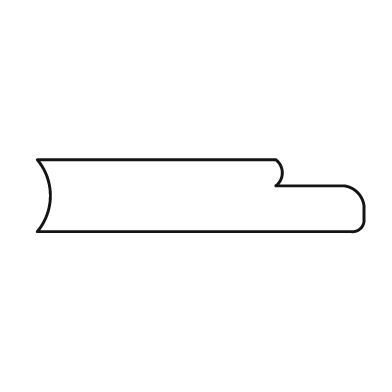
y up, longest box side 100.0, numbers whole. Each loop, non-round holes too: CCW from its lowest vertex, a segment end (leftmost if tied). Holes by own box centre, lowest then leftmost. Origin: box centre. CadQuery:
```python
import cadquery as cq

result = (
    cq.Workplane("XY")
    .moveTo(-50.0, -11.0)
    .lineTo(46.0, -11.0)
    .threePointArc((49.0, -10.0), (50.0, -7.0))
    .lineTo(50.0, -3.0)
    .threePointArc((48.0, 1.0), (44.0, 3.0))
    .lineTo(23.0, 3.0)
    .threePointArc((25.0, 7.0), (23.0, 11.0))
    .lineTo(-50.0, 11.0)
    .threePointArc((-46.0, 0.0), (-50.0, -11.0))
    .close()
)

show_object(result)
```